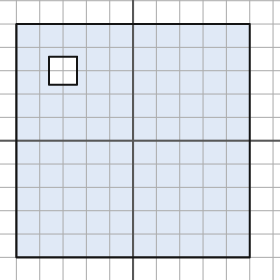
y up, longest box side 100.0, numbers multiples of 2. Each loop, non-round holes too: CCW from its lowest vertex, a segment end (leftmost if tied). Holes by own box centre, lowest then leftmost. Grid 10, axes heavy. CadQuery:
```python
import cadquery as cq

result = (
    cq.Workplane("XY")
    .moveTo(-50.0, -50.0)
    .lineTo(50.0, -50.0)
    .lineTo(50.0, 50.0)
    .lineTo(-50.0, 50.0)
    .close()
    .moveTo(-36.0, 24.0)
    .lineTo(-24.0, 24.0)
    .lineTo(-24.0, 36.0)
    .lineTo(-36.0, 36.0)
    .close()
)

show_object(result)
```